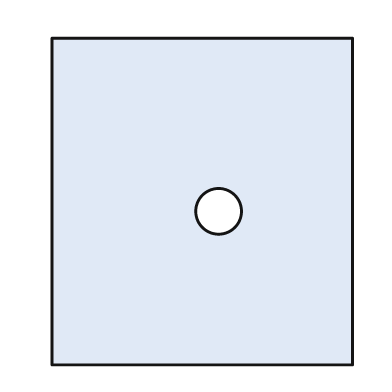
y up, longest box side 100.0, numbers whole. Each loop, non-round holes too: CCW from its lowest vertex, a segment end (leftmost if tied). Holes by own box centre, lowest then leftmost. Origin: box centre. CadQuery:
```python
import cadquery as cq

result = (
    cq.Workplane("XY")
    .moveTo(-46.0, -50.0)
    .lineTo(46.0, -50.0)
    .lineTo(46.0, 50.0)
    .lineTo(-46.0, 50.0)
    .close()
    .moveTo(5.0, -3.0)
    .circle(7.0)
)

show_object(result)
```